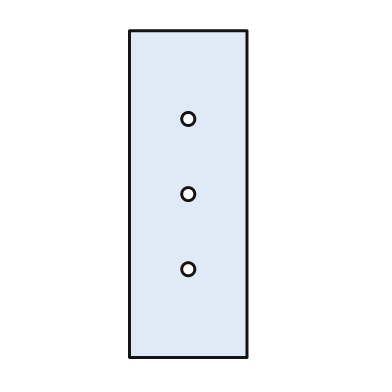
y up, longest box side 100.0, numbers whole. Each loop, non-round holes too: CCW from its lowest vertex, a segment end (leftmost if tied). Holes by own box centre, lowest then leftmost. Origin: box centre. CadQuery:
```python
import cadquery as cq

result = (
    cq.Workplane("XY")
    .moveTo(-18.0, -50.0)
    .lineTo(18.0, -50.0)
    .lineTo(18.0, 50.0)
    .lineTo(-18.0, 50.0)
    .close()
    .moveTo(0.0, -23.0)
    .circle(2.0)
    .moveTo(0.0, 0.0)
    .circle(2.0)
    .moveTo(0.0, 23.0)
    .circle(2.0)
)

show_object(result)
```